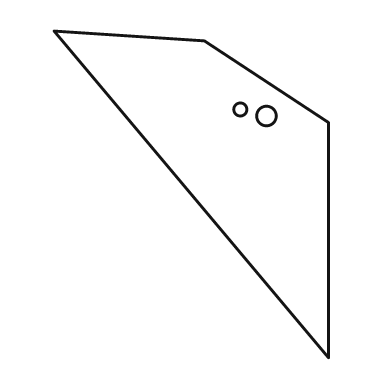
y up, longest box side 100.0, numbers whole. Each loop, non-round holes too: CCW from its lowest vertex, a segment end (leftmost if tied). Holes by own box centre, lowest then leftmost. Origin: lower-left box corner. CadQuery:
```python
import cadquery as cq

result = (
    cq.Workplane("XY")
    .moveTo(84.0, 0.0)
    .lineTo(84.0, 72.0)
    .lineTo(46.0, 97.0)
    .lineTo(0.0, 100.0)
    .close()
    .moveTo(65.0, 74.0)
    .circle(3.0)
    .moveTo(57.0, 76.0)
    .circle(2.0)
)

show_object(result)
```